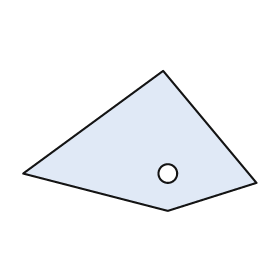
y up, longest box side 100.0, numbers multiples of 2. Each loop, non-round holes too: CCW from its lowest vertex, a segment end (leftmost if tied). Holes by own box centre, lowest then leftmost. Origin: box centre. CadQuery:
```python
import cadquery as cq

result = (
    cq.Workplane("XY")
    .moveTo(12.0, -30.0)
    .lineTo(50.0, -18.0)
    .lineTo(10.0, 30.0)
    .lineTo(-50.0, -14.0)
    .close()
    .moveTo(12.0, -14.0)
    .circle(4.0)
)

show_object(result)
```